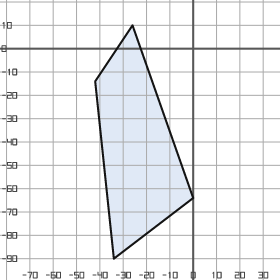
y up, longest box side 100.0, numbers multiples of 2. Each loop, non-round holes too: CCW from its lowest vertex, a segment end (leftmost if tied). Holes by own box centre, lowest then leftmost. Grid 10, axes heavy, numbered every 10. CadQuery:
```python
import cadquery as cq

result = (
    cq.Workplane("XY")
    .moveTo(-34.0, -90.0)
    .lineTo(0.0, -64.0)
    .lineTo(-26.0, 10.0)
    .lineTo(-42.0, -14.0)
    .close()
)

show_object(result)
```